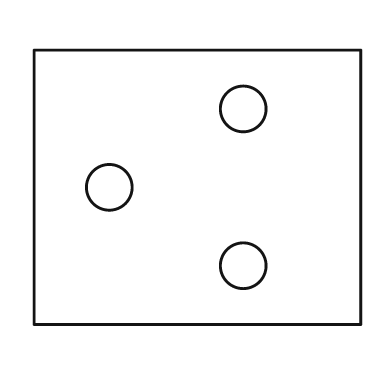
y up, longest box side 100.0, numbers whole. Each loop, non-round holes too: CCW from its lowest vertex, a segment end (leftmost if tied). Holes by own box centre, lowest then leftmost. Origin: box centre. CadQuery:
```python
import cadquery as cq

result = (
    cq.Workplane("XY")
    .moveTo(-50.0, -42.0)
    .lineTo(50.0, -42.0)
    .lineTo(50.0, 42.0)
    .lineTo(-50.0, 42.0)
    .close()
    .moveTo(14.0, -24.0)
    .circle(7.0)
    .moveTo(-27.0, 0.0)
    .circle(7.0)
    .moveTo(14.0, 24.0)
    .circle(7.0)
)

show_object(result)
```